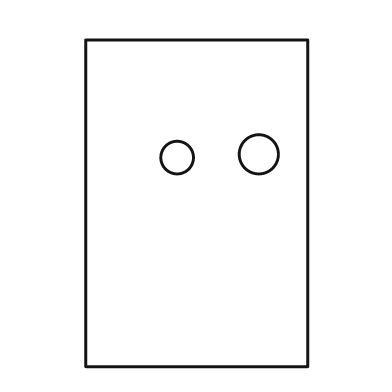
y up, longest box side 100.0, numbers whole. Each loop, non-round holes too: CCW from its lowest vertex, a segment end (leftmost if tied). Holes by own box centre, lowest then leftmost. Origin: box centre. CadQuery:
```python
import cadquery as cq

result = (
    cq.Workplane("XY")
    .moveTo(-34.0, -50.0)
    .lineTo(34.0, -50.0)
    .lineTo(34.0, 50.0)
    .lineTo(-34.0, 50.0)
    .close()
    .moveTo(-6.0, 14.0)
    .circle(5.0)
    .moveTo(19.0, 15.0)
    .circle(6.0)
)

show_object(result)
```